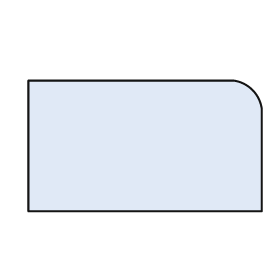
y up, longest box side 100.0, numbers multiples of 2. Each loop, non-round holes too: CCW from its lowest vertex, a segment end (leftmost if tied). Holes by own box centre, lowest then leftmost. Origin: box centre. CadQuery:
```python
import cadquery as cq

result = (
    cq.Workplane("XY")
    .moveTo(-50.0, -28.0)
    .lineTo(50.0, -28.0)
    .lineTo(50.0, 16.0)
    .threePointArc((46.0, 24.0), (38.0, 28.0))
    .lineTo(-50.0, 28.0)
    .close()
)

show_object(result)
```